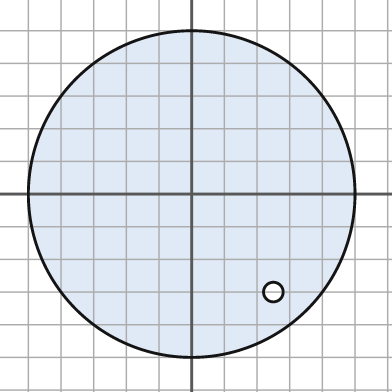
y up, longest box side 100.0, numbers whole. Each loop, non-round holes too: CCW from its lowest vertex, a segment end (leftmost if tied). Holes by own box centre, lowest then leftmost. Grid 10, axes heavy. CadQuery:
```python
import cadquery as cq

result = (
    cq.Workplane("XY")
    .moveTo(0.0, 0.0)
    .circle(50.0)
    .moveTo(25.0, -30.0)
    .circle(3.0)
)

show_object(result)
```